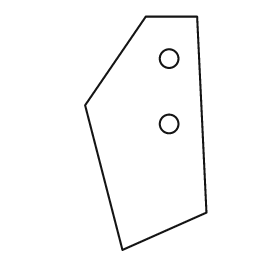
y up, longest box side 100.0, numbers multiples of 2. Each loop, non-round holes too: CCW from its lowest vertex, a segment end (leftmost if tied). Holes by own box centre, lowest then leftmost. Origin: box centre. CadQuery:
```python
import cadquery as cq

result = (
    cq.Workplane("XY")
    .moveTo(-10.0, -50.0)
    .lineTo(26.0, -34.0)
    .lineTo(22.0, 50.0)
    .lineTo(0.0, 50.0)
    .lineTo(-26.0, 12.0)
    .close()
    .moveTo(10.0, 4.0)
    .circle(4.0)
    .moveTo(10.0, 32.0)
    .circle(4.0)
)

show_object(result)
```